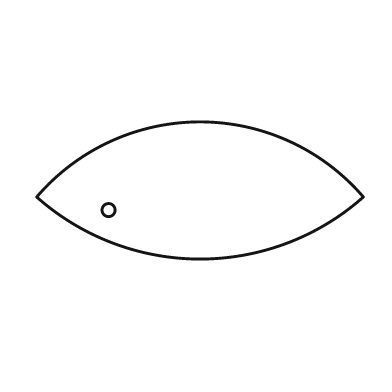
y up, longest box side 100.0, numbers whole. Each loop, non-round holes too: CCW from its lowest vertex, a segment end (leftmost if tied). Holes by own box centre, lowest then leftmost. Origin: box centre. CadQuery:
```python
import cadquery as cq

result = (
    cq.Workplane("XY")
    .moveTo(-50.0, -2.0)
    .threePointArc((0.0, -21.0), (50.0, -2.0))
    .threePointArc((0.0, 21.0), (-50.0, -2.0))
    .close()
    .moveTo(-28.0, -6.0)
    .circle(2.0)
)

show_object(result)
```